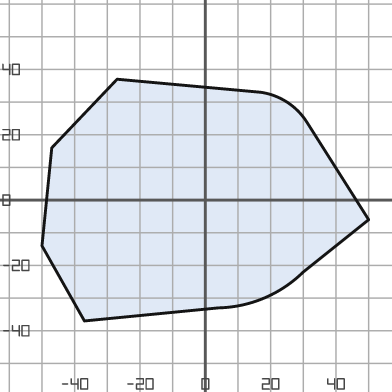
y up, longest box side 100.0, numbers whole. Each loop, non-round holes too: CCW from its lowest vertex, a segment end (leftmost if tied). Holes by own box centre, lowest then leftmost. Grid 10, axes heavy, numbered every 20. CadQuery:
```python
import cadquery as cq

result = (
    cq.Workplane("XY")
    .moveTo(-37.0, -37.0)
    .lineTo(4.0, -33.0)
    .threePointArc((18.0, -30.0), (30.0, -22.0))
    .lineTo(50.0, -6.0)
    .lineTo(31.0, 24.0)
    .threePointArc((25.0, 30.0), (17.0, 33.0))
    .lineTo(-27.0, 37.0)
    .lineTo(-47.0, 16.0)
    .lineTo(-50.0, -14.0)
    .close()
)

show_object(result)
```